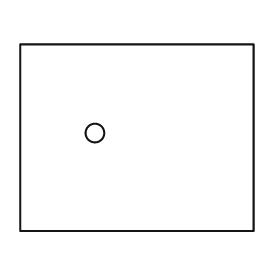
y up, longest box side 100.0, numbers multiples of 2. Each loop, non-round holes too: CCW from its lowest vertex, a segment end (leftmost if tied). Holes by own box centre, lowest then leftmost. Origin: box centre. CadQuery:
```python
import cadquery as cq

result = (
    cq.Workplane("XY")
    .moveTo(-50.0, -40.0)
    .lineTo(50.0, -40.0)
    .lineTo(50.0, 40.0)
    .lineTo(-50.0, 40.0)
    .close()
    .moveTo(-18.0, 2.0)
    .circle(4.0)
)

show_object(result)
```